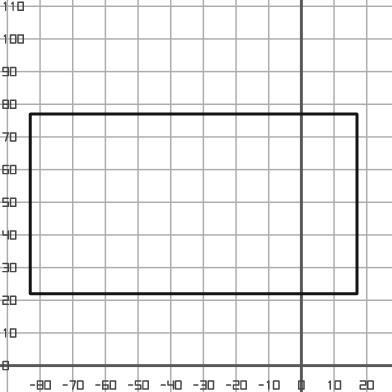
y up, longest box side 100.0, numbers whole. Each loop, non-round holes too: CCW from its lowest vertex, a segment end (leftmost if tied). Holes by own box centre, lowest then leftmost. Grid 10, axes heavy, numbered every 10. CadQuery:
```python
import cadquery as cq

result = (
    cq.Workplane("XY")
    .moveTo(-83.0, 22.0)
    .lineTo(17.0, 22.0)
    .lineTo(17.0, 77.0)
    .lineTo(-83.0, 77.0)
    .close()
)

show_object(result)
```